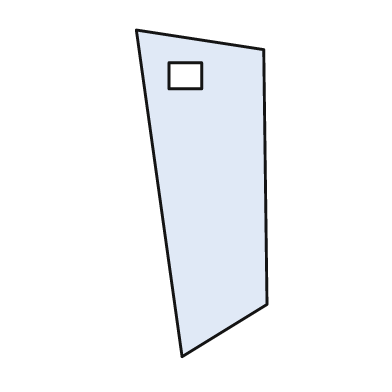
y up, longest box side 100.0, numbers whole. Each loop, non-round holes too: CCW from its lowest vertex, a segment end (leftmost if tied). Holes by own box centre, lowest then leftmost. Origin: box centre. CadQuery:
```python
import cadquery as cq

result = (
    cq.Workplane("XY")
    .moveTo(-6.0, -50.0)
    .lineTo(20.0, -34.0)
    .lineTo(19.0, 44.0)
    .lineTo(-20.0, 50.0)
    .close()
    .moveTo(-10.0, 32.0)
    .lineTo(0.0, 32.0)
    .lineTo(0.0, 40.0)
    .lineTo(-10.0, 40.0)
    .close()
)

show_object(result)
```